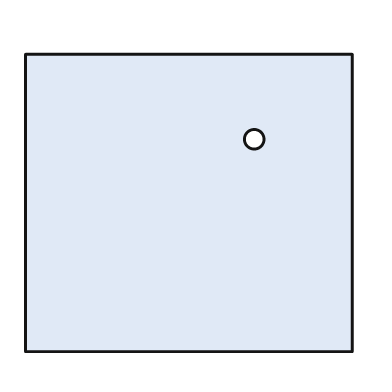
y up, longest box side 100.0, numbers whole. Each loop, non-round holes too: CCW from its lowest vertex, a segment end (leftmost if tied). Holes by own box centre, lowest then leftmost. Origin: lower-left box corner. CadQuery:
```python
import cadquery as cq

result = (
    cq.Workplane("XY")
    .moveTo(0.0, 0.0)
    .lineTo(100.0, 0.0)
    .lineTo(100.0, 91.0)
    .lineTo(0.0, 91.0)
    .close()
    .moveTo(70.0, 65.0)
    .circle(3.0)
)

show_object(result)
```